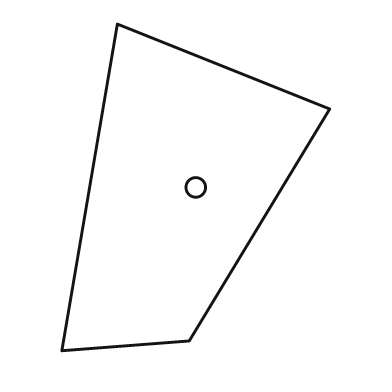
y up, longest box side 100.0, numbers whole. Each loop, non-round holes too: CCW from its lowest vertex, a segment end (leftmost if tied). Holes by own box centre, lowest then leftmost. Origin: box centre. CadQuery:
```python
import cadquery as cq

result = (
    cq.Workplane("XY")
    .moveTo(-41.0, -50.0)
    .lineTo(-2.0, -47.0)
    .lineTo(41.0, 24.0)
    .lineTo(-24.0, 50.0)
    .close()
    .moveTo(0.0, 0.0)
    .circle(3.0)
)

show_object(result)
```